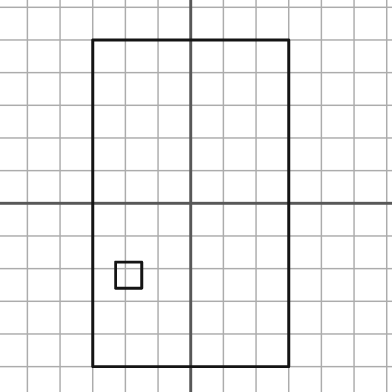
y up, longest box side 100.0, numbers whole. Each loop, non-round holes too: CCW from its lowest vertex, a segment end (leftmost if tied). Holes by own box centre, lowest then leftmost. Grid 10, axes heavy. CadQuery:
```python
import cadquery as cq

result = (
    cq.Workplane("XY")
    .moveTo(-30.0, -50.0)
    .lineTo(30.0, -50.0)
    .lineTo(30.0, 50.0)
    .lineTo(-30.0, 50.0)
    .close()
    .moveTo(-23.0, -26.0)
    .lineTo(-15.0, -26.0)
    .lineTo(-15.0, -18.0)
    .lineTo(-23.0, -18.0)
    .close()
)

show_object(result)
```